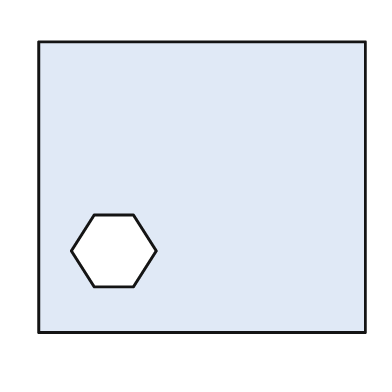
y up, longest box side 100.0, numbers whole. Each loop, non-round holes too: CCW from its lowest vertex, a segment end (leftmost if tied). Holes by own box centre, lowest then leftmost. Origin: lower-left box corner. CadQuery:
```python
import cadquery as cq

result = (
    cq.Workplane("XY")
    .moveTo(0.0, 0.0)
    .lineTo(100.0, 0.0)
    .lineTo(100.0, 89.0)
    .lineTo(0.0, 89.0)
    .close()
    .moveTo(17.0, 14.0)
    .lineTo(29.0, 14.0)
    .lineTo(36.0, 25.0)
    .lineTo(29.0, 36.0)
    .lineTo(17.0, 36.0)
    .lineTo(10.0, 25.0)
    .close()
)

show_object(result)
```